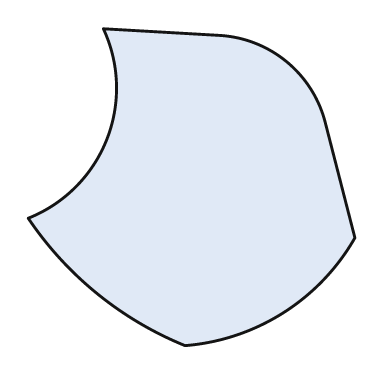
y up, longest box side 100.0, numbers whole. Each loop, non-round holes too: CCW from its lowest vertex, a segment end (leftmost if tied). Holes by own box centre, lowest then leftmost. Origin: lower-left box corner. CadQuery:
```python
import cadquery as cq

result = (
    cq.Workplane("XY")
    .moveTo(48.0, 0.0)
    .threePointArc((78.0, 10.0), (100.0, 33.0))
    .lineTo(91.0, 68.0)
    .threePointArc((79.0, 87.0), (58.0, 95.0))
    .lineTo(23.0, 97.0)
    .threePointArc((24.0, 63.0), (0.0, 39.0))
    .threePointArc((21.0, 16.0), (48.0, 0.0))
    .close()
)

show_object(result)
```